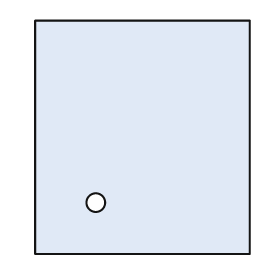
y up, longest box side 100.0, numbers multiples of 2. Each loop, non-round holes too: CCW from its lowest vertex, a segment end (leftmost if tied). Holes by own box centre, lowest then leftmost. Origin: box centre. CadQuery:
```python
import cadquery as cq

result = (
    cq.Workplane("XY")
    .moveTo(-46.0, -50.0)
    .lineTo(46.0, -50.0)
    .lineTo(46.0, 50.0)
    .lineTo(-46.0, 50.0)
    .close()
    .moveTo(-20.0, -28.0)
    .circle(4.0)
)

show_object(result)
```